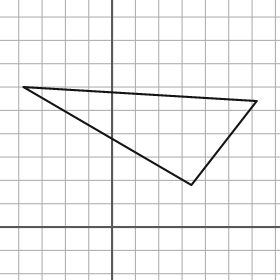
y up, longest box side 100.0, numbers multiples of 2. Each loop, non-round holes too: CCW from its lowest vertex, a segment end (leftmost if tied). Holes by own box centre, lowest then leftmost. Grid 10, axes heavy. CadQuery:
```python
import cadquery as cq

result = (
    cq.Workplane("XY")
    .moveTo(34.0, 18.0)
    .lineTo(62.0, 54.0)
    .lineTo(-38.0, 60.0)
    .close()
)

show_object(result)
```